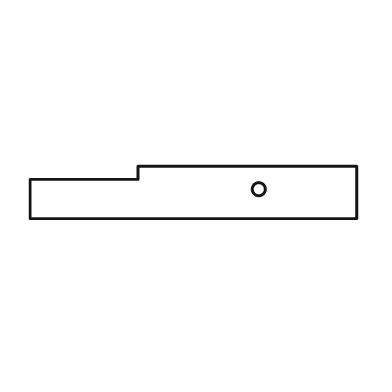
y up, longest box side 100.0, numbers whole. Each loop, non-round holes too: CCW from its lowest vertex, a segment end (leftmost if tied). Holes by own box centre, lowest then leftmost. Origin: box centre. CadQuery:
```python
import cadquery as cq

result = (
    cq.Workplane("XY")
    .moveTo(-50.0, -8.0)
    .lineTo(50.0, -8.0)
    .lineTo(50.0, 8.0)
    .lineTo(-17.0, 8.0)
    .lineTo(-17.0, 4.0)
    .lineTo(-50.0, 4.0)
    .close()
    .moveTo(20.0, 1.0)
    .circle(2.0)
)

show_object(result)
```